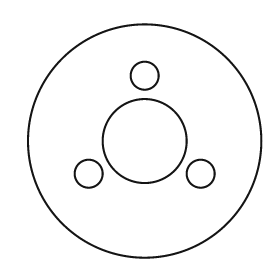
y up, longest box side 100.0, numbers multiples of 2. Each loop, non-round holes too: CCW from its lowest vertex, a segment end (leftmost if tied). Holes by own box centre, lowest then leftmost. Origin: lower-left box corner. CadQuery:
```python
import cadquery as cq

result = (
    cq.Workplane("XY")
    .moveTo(50.0, 50.0)
    .circle(50.0)
    .moveTo(26.0, 36.0)
    .circle(6.0)
    .moveTo(74.0, 36.0)
    .circle(6.0)
    .moveTo(50.0, 50.0)
    .circle(18.0)
    .moveTo(50.0, 78.0)
    .circle(6.0)
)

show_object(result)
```